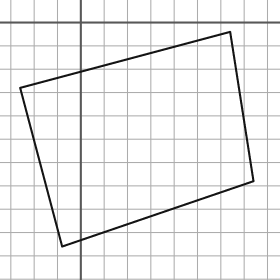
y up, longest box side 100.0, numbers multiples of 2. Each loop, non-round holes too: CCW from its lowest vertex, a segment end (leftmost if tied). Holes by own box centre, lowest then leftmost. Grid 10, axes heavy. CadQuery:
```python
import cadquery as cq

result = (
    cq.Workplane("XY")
    .moveTo(-8.0, -96.0)
    .lineTo(74.0, -68.0)
    .lineTo(64.0, -4.0)
    .lineTo(-26.0, -28.0)
    .close()
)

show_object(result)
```